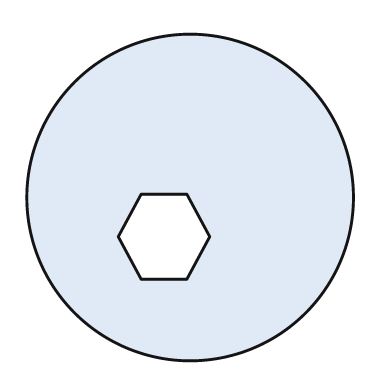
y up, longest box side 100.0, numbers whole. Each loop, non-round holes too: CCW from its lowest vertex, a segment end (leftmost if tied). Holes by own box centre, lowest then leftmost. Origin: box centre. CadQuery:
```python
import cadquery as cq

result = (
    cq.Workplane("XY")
    .moveTo(0.0, 0.0)
    .circle(50.0)
    .moveTo(-15.0, -25.0)
    .lineTo(-1.0, -25.0)
    .lineTo(6.0, -12.0)
    .lineTo(-1.0, 1.0)
    .lineTo(-15.0, 1.0)
    .lineTo(-22.0, -12.0)
    .close()
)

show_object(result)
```